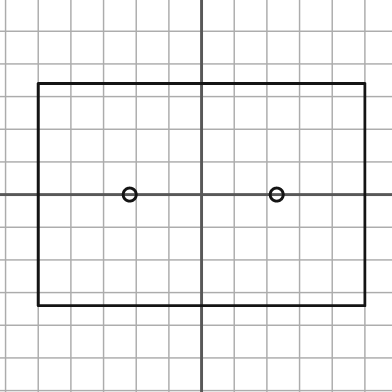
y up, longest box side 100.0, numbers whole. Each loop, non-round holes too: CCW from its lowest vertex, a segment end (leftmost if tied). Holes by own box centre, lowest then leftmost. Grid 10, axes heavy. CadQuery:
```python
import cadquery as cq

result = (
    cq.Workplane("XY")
    .moveTo(-50.0, -34.0)
    .lineTo(50.0, -34.0)
    .lineTo(50.0, 34.0)
    .lineTo(-50.0, 34.0)
    .close()
    .moveTo(-22.0, 0.0)
    .circle(2.0)
    .moveTo(23.0, 0.0)
    .circle(2.0)
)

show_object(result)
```